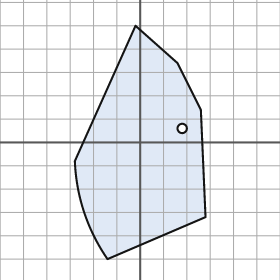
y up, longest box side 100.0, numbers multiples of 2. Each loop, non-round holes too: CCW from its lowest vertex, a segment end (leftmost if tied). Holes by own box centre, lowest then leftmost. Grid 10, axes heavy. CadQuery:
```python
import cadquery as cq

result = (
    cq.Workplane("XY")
    .moveTo(-14.0, -50.0)
    .lineTo(28.0, -32.0)
    .lineTo(26.0, 14.0)
    .lineTo(16.0, 34.0)
    .lineTo(-2.0, 50.0)
    .lineTo(-28.0, -8.0)
    .threePointArc((-24.0, -30.0), (-14.0, -50.0))
    .close()
    .moveTo(18.0, 6.0)
    .circle(2.0)
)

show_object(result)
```